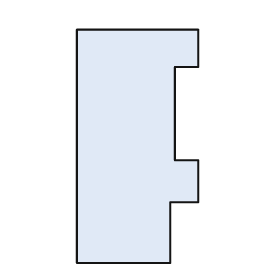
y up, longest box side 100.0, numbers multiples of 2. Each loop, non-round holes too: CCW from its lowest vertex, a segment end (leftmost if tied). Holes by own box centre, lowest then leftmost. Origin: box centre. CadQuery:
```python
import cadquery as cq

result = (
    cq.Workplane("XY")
    .moveTo(-26.0, -50.0)
    .lineTo(14.0, -50.0)
    .lineTo(14.0, -24.0)
    .lineTo(26.0, -24.0)
    .lineTo(26.0, -6.0)
    .lineTo(16.0, -6.0)
    .lineTo(16.0, 34.0)
    .lineTo(26.0, 34.0)
    .lineTo(26.0, 50.0)
    .lineTo(-26.0, 50.0)
    .close()
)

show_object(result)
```